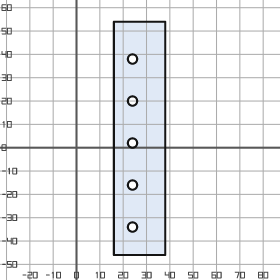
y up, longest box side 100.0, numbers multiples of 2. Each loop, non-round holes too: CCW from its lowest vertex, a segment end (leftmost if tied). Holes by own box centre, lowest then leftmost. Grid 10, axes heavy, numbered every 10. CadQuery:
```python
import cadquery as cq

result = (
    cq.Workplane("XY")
    .moveTo(16.0, -46.0)
    .lineTo(38.0, -46.0)
    .lineTo(38.0, 54.0)
    .lineTo(16.0, 54.0)
    .close()
    .moveTo(24.0, -34.0)
    .circle(2.0)
    .moveTo(24.0, -16.0)
    .circle(2.0)
    .moveTo(24.0, 2.0)
    .circle(2.0)
    .moveTo(24.0, 20.0)
    .circle(2.0)
    .moveTo(24.0, 38.0)
    .circle(2.0)
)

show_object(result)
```